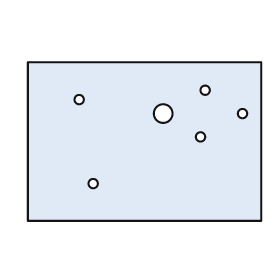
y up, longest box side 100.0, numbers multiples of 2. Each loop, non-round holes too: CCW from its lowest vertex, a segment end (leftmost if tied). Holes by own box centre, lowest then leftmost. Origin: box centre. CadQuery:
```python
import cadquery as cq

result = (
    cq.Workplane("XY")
    .moveTo(-50.0, -34.0)
    .lineTo(50.0, -34.0)
    .lineTo(50.0, 34.0)
    .lineTo(-50.0, 34.0)
    .close()
    .moveTo(-22.0, -18.0)
    .circle(2.0)
    .moveTo(24.0, 2.0)
    .circle(2.0)
    .moveTo(8.0, 12.0)
    .circle(4.0)
    .moveTo(42.0, 12.0)
    .circle(2.0)
    .moveTo(-28.0, 18.0)
    .circle(2.0)
    .moveTo(26.0, 22.0)
    .circle(2.0)
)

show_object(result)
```